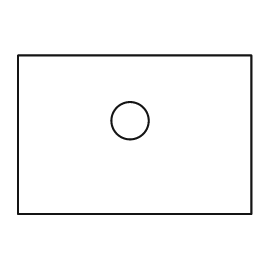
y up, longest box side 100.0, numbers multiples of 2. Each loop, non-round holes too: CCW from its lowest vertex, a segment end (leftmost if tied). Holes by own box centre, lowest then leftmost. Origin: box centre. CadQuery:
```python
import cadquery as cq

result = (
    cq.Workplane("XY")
    .moveTo(-50.0, -34.0)
    .lineTo(50.0, -34.0)
    .lineTo(50.0, 34.0)
    .lineTo(-50.0, 34.0)
    .close()
    .moveTo(-2.0, 6.0)
    .circle(8.0)
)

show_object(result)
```